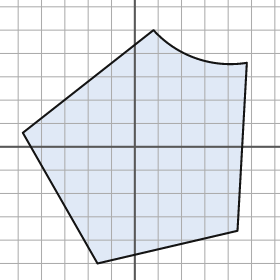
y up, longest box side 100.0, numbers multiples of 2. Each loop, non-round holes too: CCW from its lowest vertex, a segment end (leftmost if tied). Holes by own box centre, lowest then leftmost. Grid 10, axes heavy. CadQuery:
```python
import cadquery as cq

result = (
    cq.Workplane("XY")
    .moveTo(-16.0, -50.0)
    .lineTo(44.0, -36.0)
    .lineTo(48.0, 36.0)
    .threePointArc((26.0, 38.0), (8.0, 50.0))
    .lineTo(-48.0, 6.0)
    .close()
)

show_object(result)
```